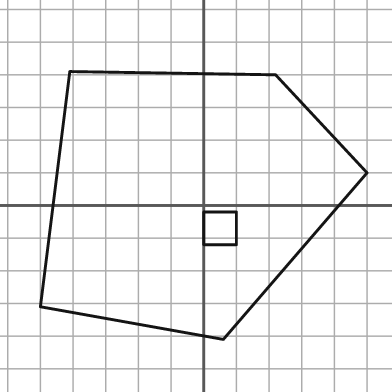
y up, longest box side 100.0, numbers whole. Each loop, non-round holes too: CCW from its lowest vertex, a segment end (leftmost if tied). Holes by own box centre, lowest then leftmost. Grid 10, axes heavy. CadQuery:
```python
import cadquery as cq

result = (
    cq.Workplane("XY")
    .moveTo(6.0, -41.0)
    .lineTo(50.0, 10.0)
    .lineTo(22.0, 40.0)
    .lineTo(-41.0, 41.0)
    .lineTo(-50.0, -31.0)
    .close()
    .moveTo(0.0, -12.0)
    .lineTo(10.0, -12.0)
    .lineTo(10.0, -2.0)
    .lineTo(0.0, -2.0)
    .close()
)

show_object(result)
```